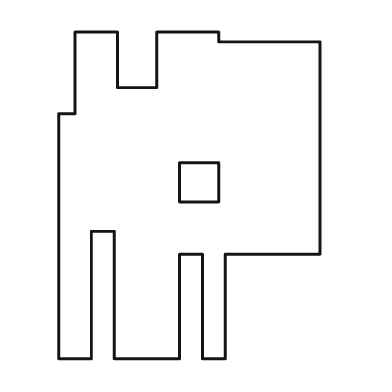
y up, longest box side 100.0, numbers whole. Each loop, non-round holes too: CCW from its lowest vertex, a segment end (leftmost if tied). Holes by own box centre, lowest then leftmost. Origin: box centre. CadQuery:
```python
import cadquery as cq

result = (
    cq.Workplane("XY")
    .moveTo(-40.0, -50.0)
    .lineTo(-30.0, -50.0)
    .lineTo(-30.0, -11.0)
    .lineTo(-23.0, -11.0)
    .lineTo(-23.0, -50.0)
    .lineTo(-3.0, -50.0)
    .lineTo(-3.0, -18.0)
    .lineTo(4.0, -18.0)
    .lineTo(4.0, -50.0)
    .lineTo(11.0, -50.0)
    .lineTo(11.0, -18.0)
    .lineTo(40.0, -18.0)
    .lineTo(40.0, 47.0)
    .lineTo(9.0, 47.0)
    .lineTo(9.0, 50.0)
    .lineTo(-10.0, 50.0)
    .lineTo(-10.0, 33.0)
    .lineTo(-22.0, 33.0)
    .lineTo(-22.0, 50.0)
    .lineTo(-35.0, 50.0)
    .lineTo(-35.0, 25.0)
    .lineTo(-40.0, 25.0)
    .close()
    .moveTo(-3.0, -2.0)
    .lineTo(9.0, -2.0)
    .lineTo(9.0, 10.0)
    .lineTo(-3.0, 10.0)
    .close()
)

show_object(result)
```